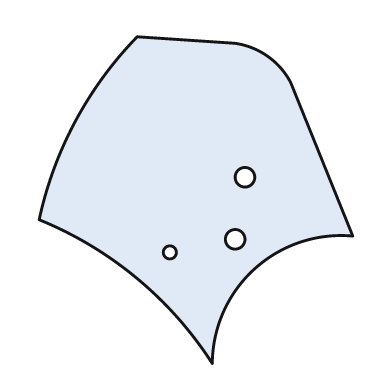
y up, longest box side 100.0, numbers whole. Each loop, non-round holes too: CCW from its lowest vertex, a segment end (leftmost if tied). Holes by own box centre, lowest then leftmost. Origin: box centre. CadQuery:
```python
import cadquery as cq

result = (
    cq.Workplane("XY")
    .moveTo(5.0, -50.0)
    .threePointArc((18.0, -21.0), (48.0, -11.0))
    .lineTo(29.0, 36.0)
    .threePointArc((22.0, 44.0), (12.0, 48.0))
    .lineTo(-18.0, 50.0)
    .threePointArc((-37.0, 24.0), (-48.0, -6.0))
    .threePointArc((-18.0, -24.0), (5.0, -50.0))
    .close()
    .moveTo(-8.0, -16.0)
    .circle(2.0)
    .moveTo(12.0, -12.0)
    .circle(3.0)
    .moveTo(15.0, 7.0)
    .circle(3.0)
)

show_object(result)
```